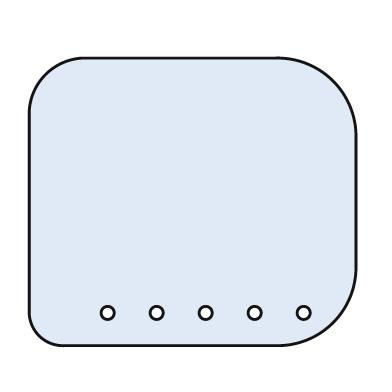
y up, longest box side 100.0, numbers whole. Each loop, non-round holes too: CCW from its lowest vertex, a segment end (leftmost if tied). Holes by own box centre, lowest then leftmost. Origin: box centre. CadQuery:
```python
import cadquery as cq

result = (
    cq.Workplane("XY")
    .moveTo(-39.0, -44.0)
    .lineTo(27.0, -44.0)
    .threePointArc((43.0, -37.0), (50.0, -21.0))
    .lineTo(50.0, 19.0)
    .threePointArc((43.0, 37.0), (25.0, 44.0))
    .lineTo(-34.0, 44.0)
    .threePointArc((-45.0, 39.0), (-50.0, 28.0))
    .lineTo(-50.0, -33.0)
    .threePointArc((-47.0, -41.0), (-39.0, -44.0))
    .close()
    .moveTo(-26.0, -34.0)
    .circle(2.0)
    .moveTo(-11.0, -34.0)
    .circle(2.0)
    .moveTo(4.0, -34.0)
    .circle(2.0)
    .moveTo(19.0, -34.0)
    .circle(2.0)
    .moveTo(34.0, -34.0)
    .circle(2.0)
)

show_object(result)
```